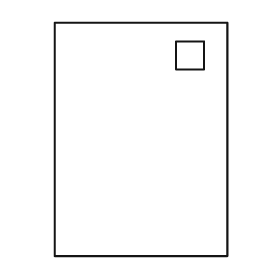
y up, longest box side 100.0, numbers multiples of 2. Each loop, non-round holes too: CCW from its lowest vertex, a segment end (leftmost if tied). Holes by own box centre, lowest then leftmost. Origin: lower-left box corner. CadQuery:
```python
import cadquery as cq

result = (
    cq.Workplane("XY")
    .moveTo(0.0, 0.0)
    .lineTo(74.0, 0.0)
    .lineTo(74.0, 100.0)
    .lineTo(0.0, 100.0)
    .close()
    .moveTo(52.0, 80.0)
    .lineTo(64.0, 80.0)
    .lineTo(64.0, 92.0)
    .lineTo(52.0, 92.0)
    .close()
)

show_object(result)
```